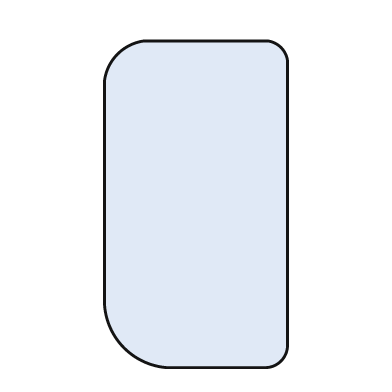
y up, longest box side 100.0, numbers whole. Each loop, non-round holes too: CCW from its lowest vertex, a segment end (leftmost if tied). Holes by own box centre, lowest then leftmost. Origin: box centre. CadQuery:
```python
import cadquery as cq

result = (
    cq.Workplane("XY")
    .moveTo(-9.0, -50.0)
    .lineTo(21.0, -50.0)
    .threePointArc((26.0, -48.0), (28.0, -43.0))
    .lineTo(28.0, 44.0)
    .threePointArc((26.0, 48.0), (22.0, 50.0))
    .lineTo(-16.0, 50.0)
    .threePointArc((-24.0, 46.0), (-28.0, 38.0))
    .lineTo(-28.0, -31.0)
    .threePointArc((-22.0, -44.0), (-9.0, -50.0))
    .close()
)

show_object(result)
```